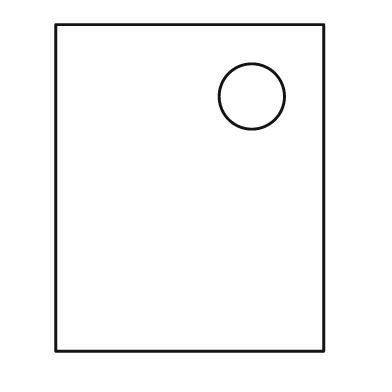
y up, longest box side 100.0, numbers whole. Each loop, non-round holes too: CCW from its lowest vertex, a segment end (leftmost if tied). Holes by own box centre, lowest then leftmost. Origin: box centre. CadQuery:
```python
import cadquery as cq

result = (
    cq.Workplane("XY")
    .moveTo(-41.0, -50.0)
    .lineTo(41.0, -50.0)
    .lineTo(41.0, 50.0)
    .lineTo(-41.0, 50.0)
    .close()
    .moveTo(19.0, 28.0)
    .circle(10.0)
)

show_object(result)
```